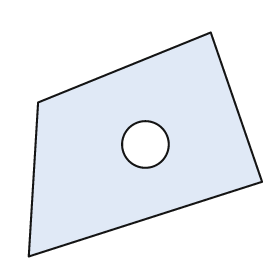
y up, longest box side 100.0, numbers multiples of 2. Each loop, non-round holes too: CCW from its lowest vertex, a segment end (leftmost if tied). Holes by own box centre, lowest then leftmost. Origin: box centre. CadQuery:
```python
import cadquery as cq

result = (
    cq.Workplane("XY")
    .moveTo(-50.0, -48.0)
    .lineTo(50.0, -16.0)
    .lineTo(28.0, 48.0)
    .lineTo(-46.0, 18.0)
    .close()
    .moveTo(0.0, 0.0)
    .circle(10.0)
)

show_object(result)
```